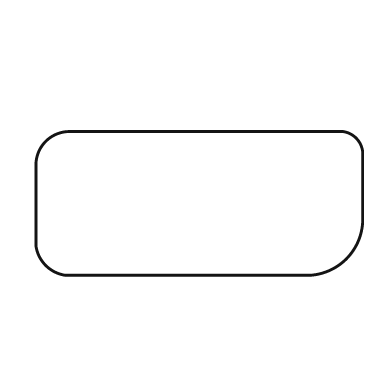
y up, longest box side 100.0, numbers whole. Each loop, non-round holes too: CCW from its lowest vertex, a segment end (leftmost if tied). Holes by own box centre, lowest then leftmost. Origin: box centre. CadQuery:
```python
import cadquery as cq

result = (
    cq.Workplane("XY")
    .moveTo(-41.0, -22.0)
    .lineTo(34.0, -22.0)
    .threePointArc((45.0, -17.0), (50.0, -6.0))
    .lineTo(50.0, 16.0)
    .threePointArc((48.0, 20.0), (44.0, 22.0))
    .lineTo(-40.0, 22.0)
    .threePointArc((-47.0, 19.0), (-50.0, 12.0))
    .lineTo(-50.0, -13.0)
    .threePointArc((-47.0, -19.0), (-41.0, -22.0))
    .close()
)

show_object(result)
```